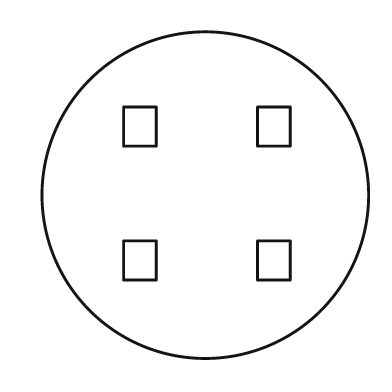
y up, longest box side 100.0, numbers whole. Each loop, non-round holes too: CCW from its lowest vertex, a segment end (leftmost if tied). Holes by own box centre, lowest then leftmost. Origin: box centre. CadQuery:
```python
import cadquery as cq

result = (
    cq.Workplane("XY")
    .moveTo(0.0, 0.0)
    .circle(50.0)
    .moveTo(-25.0, -26.0)
    .lineTo(-15.0, -26.0)
    .lineTo(-15.0, -14.0)
    .lineTo(-25.0, -14.0)
    .close()
    .moveTo(16.0, -26.0)
    .lineTo(26.0, -26.0)
    .lineTo(26.0, -14.0)
    .lineTo(16.0, -14.0)
    .close()
    .moveTo(-25.0, 15.0)
    .lineTo(-15.0, 15.0)
    .lineTo(-15.0, 27.0)
    .lineTo(-25.0, 27.0)
    .close()
    .moveTo(16.0, 15.0)
    .lineTo(26.0, 15.0)
    .lineTo(26.0, 27.0)
    .lineTo(16.0, 27.0)
    .close()
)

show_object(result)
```